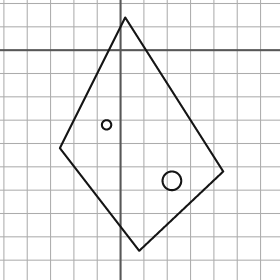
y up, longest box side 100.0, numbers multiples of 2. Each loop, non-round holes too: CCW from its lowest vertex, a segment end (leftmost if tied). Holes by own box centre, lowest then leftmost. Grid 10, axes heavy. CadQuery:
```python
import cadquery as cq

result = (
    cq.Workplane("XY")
    .moveTo(8.0, -86.0)
    .lineTo(44.0, -52.0)
    .lineTo(2.0, 14.0)
    .lineTo(-26.0, -42.0)
    .close()
    .moveTo(22.0, -56.0)
    .circle(4.0)
    .moveTo(-6.0, -32.0)
    .circle(2.0)
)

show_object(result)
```